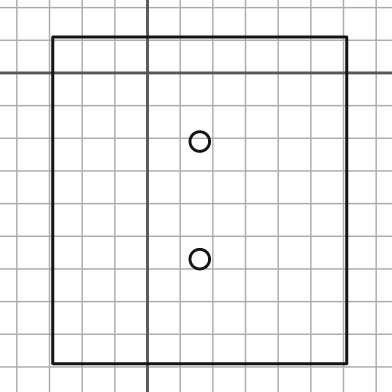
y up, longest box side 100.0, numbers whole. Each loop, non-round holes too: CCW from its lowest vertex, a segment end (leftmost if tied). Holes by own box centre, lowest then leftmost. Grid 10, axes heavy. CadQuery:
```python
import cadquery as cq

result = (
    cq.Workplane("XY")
    .moveTo(-29.0, -89.0)
    .lineTo(61.0, -89.0)
    .lineTo(61.0, 11.0)
    .lineTo(-29.0, 11.0)
    .close()
    .moveTo(16.0, -57.0)
    .circle(3.0)
    .moveTo(16.0, -21.0)
    .circle(3.0)
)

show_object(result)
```